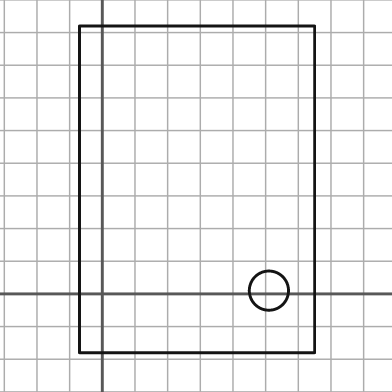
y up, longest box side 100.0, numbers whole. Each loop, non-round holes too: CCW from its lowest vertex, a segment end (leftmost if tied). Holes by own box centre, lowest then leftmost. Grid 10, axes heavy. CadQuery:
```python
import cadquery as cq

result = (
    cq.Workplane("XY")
    .moveTo(-7.0, -18.0)
    .lineTo(65.0, -18.0)
    .lineTo(65.0, 82.0)
    .lineTo(-7.0, 82.0)
    .close()
    .moveTo(51.0, 1.0)
    .circle(6.0)
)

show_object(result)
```